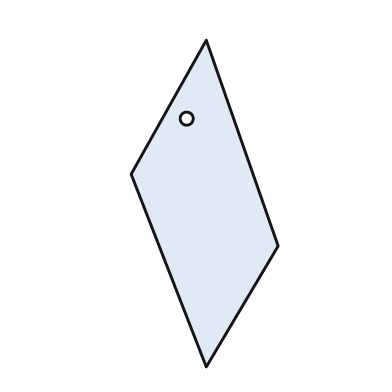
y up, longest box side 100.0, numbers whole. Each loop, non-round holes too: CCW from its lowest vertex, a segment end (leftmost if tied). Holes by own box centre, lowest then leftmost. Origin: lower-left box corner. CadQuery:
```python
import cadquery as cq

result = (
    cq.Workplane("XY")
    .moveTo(23.0, 0.0)
    .lineTo(45.0, 37.0)
    .lineTo(23.0, 100.0)
    .lineTo(0.0, 59.0)
    .close()
    .moveTo(17.0, 76.0)
    .circle(2.0)
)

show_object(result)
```